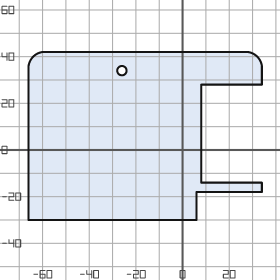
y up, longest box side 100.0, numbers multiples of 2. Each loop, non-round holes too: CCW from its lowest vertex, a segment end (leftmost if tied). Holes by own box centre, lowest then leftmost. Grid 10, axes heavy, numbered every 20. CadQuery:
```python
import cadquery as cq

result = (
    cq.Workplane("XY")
    .moveTo(-66.0, -30.0)
    .lineTo(6.0, -30.0)
    .lineTo(6.0, -18.0)
    .lineTo(34.0, -18.0)
    .lineTo(34.0, -14.0)
    .lineTo(8.0, -14.0)
    .lineTo(8.0, 28.0)
    .lineTo(34.0, 28.0)
    .lineTo(34.0, 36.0)
    .threePointArc((32.0, 40.0), (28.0, 42.0))
    .lineTo(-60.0, 42.0)
    .threePointArc((-64.0, 40.0), (-66.0, 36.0))
    .close()
    .moveTo(-26.0, 34.0)
    .circle(2.0)
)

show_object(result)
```